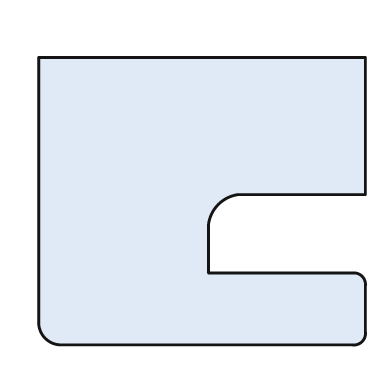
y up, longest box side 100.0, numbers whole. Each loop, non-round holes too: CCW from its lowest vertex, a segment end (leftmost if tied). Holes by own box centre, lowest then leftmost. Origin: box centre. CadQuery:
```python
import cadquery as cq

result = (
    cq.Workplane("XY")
    .moveTo(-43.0, -44.0)
    .lineTo(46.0, -44.0)
    .threePointArc((49.0, -43.0), (50.0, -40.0))
    .lineTo(50.0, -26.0)
    .threePointArc((49.0, -23.0), (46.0, -22.0))
    .lineTo(2.0, -22.0)
    .lineTo(2.0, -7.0)
    .threePointArc((5.0, -1.0), (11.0, 2.0))
    .lineTo(50.0, 2.0)
    .lineTo(50.0, 44.0)
    .lineTo(-50.0, 44.0)
    .lineTo(-50.0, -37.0)
    .threePointArc((-48.0, -42.0), (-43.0, -44.0))
    .close()
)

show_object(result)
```